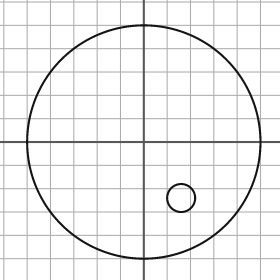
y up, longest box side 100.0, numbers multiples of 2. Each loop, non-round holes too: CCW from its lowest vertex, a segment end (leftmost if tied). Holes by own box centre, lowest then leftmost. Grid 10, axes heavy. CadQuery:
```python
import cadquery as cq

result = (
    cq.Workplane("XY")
    .moveTo(0.0, 0.0)
    .circle(50.0)
    .moveTo(16.0, -24.0)
    .circle(6.0)
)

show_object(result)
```